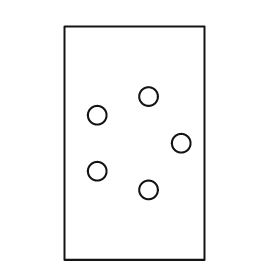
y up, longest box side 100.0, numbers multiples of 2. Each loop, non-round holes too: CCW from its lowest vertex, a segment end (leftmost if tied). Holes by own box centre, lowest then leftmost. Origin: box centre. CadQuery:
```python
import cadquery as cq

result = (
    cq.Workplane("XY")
    .moveTo(-30.0, -50.0)
    .lineTo(30.0, -50.0)
    .lineTo(30.0, 50.0)
    .lineTo(-30.0, 50.0)
    .close()
    .moveTo(6.0, -20.0)
    .circle(4.0)
    .moveTo(-16.0, -12.0)
    .circle(4.0)
    .moveTo(20.0, 0.0)
    .circle(4.0)
    .moveTo(-16.0, 12.0)
    .circle(4.0)
    .moveTo(6.0, 20.0)
    .circle(4.0)
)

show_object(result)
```